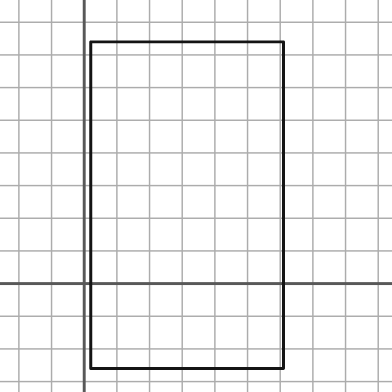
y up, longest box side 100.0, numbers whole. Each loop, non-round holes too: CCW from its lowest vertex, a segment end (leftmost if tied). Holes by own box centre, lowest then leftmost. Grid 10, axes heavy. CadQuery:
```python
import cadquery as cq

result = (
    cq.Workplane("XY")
    .moveTo(2.0, -26.0)
    .lineTo(61.0, -26.0)
    .lineTo(61.0, 74.0)
    .lineTo(2.0, 74.0)
    .close()
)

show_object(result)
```